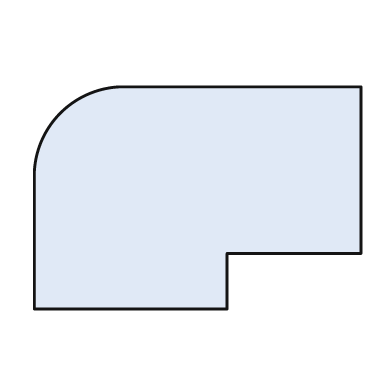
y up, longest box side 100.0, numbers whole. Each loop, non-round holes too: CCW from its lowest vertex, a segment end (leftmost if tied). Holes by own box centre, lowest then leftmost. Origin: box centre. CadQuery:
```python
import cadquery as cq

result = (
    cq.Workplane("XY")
    .moveTo(-50.0, -34.0)
    .lineTo(9.0, -34.0)
    .lineTo(9.0, -17.0)
    .lineTo(50.0, -17.0)
    .lineTo(50.0, 34.0)
    .lineTo(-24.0, 34.0)
    .threePointArc((-42.0, 26.0), (-50.0, 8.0))
    .close()
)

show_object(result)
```